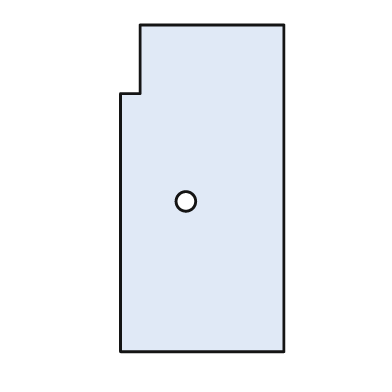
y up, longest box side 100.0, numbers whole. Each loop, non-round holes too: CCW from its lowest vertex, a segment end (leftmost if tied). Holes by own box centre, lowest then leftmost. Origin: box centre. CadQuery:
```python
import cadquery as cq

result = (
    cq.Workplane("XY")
    .moveTo(-25.0, -50.0)
    .lineTo(25.0, -50.0)
    .lineTo(25.0, 50.0)
    .lineTo(-19.0, 50.0)
    .lineTo(-19.0, 29.0)
    .lineTo(-25.0, 29.0)
    .close()
    .moveTo(-5.0, -4.0)
    .circle(3.0)
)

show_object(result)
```